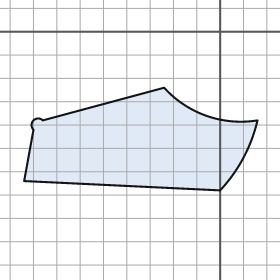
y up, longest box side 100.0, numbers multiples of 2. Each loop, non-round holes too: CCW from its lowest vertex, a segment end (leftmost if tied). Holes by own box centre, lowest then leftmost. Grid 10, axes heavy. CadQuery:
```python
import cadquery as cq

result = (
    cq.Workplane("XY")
    .moveTo(0.0, -68.0)
    .threePointArc((10.0, -54.0), (16.0, -38.0))
    .threePointArc((-6.0, -36.0), (-24.0, -24.0))
    .lineTo(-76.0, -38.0)
    .threePointArc((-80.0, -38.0), (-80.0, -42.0))
    .lineTo(-84.0, -64.0)
    .close()
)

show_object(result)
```